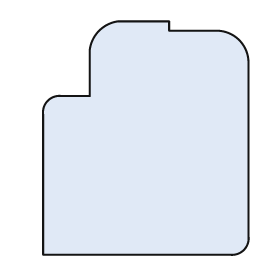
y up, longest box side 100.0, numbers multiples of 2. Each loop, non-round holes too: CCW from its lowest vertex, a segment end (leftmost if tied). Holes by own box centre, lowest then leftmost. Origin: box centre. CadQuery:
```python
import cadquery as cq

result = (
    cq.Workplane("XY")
    .moveTo(-44.0, -50.0)
    .lineTo(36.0, -50.0)
    .threePointArc((42.0, -48.0), (44.0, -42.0))
    .lineTo(44.0, 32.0)
    .threePointArc((40.0, 42.0), (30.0, 46.0))
    .lineTo(10.0, 46.0)
    .lineTo(10.0, 50.0)
    .lineTo(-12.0, 50.0)
    .threePointArc((-20.0, 46.0), (-24.0, 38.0))
    .lineTo(-24.0, 18.0)
    .lineTo(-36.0, 18.0)
    .threePointArc((-42.0, 16.0), (-44.0, 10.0))
    .close()
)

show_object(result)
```